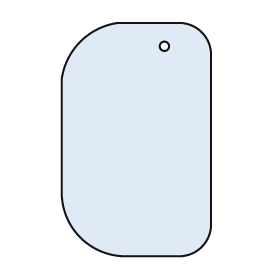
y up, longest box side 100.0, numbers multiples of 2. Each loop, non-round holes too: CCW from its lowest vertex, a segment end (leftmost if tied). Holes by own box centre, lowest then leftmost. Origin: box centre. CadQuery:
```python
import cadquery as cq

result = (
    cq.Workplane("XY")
    .moveTo(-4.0, -50.0)
    .lineTo(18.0, -50.0)
    .threePointArc((28.0, -46.0), (32.0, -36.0))
    .lineTo(32.0, 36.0)
    .threePointArc((28.0, 46.0), (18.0, 50.0))
    .lineTo(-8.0, 50.0)
    .threePointArc((-24.0, 42.0), (-32.0, 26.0))
    .lineTo(-32.0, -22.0)
    .threePointArc((-24.0, -42.0), (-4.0, -50.0))
    .close()
    .moveTo(12.0, 40.0)
    .circle(2.0)
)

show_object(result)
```